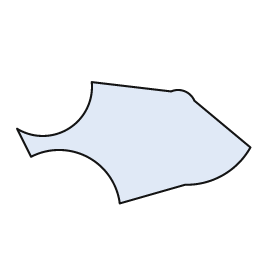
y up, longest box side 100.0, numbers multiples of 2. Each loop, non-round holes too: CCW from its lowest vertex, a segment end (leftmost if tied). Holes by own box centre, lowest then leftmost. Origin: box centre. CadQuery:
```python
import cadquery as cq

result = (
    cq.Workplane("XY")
    .moveTo(-6.0, -26.0)
    .lineTo(22.0, -18.0)
    .threePointArc((38.0, -14.0), (50.0, -2.0))
    .lineTo(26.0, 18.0)
    .threePointArc((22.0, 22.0), (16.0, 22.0))
    .lineTo(-18.0, 26.0)
    .threePointArc((-28.0, 6.0), (-50.0, 6.0))
    .lineTo(-44.0, -6.0)
    .threePointArc((-20.0, -6.0), (-6.0, -26.0))
    .close()
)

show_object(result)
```